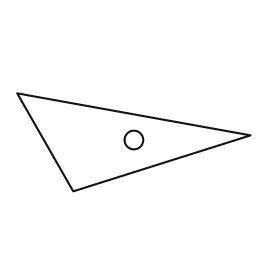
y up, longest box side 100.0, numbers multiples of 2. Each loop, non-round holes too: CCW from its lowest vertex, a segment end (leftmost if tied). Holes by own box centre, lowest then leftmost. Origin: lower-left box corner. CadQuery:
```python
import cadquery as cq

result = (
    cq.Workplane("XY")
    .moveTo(24.0, 0.0)
    .lineTo(100.0, 24.0)
    .lineTo(0.0, 42.0)
    .close()
    .moveTo(50.0, 22.0)
    .circle(4.0)
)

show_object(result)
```